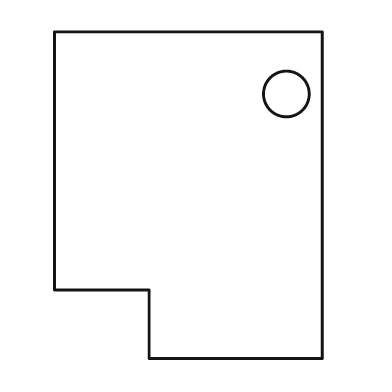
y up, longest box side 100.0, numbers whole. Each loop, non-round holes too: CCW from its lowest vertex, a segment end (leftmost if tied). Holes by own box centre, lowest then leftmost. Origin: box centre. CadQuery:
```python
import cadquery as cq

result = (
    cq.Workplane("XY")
    .moveTo(-12.0, -50.0)
    .lineTo(41.0, -50.0)
    .lineTo(41.0, 50.0)
    .lineTo(-41.0, 50.0)
    .lineTo(-41.0, -29.0)
    .lineTo(-12.0, -29.0)
    .close()
    .moveTo(30.0, 31.0)
    .circle(7.0)
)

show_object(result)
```